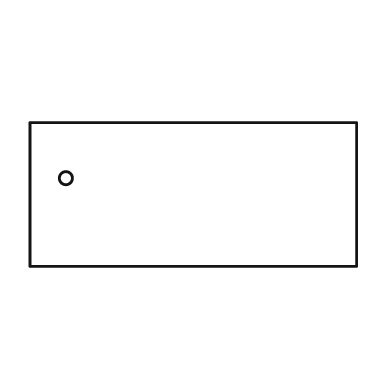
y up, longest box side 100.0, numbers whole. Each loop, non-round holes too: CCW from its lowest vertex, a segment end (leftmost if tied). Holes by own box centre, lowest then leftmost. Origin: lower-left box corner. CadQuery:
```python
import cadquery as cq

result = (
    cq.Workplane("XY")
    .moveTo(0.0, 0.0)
    .lineTo(100.0, 0.0)
    .lineTo(100.0, 44.0)
    .lineTo(0.0, 44.0)
    .close()
    .moveTo(11.0, 27.0)
    .circle(2.0)
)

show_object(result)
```